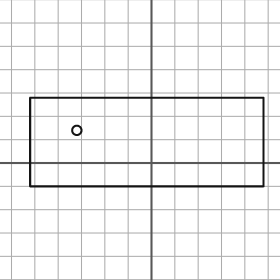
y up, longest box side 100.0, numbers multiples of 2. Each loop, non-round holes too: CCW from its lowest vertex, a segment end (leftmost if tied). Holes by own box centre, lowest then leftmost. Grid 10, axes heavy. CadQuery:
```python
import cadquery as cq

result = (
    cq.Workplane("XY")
    .moveTo(-52.0, -10.0)
    .lineTo(48.0, -10.0)
    .lineTo(48.0, 28.0)
    .lineTo(-52.0, 28.0)
    .close()
    .moveTo(-32.0, 14.0)
    .circle(2.0)
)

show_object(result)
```